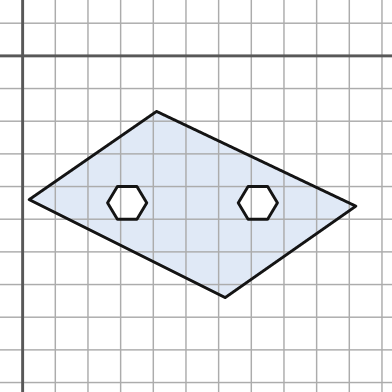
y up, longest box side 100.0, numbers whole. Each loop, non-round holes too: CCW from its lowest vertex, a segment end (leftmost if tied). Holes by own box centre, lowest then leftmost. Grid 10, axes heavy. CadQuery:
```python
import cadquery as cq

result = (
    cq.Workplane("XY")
    .moveTo(62.0, -74.0)
    .lineTo(102.0, -46.0)
    .lineTo(41.0, -17.0)
    .lineTo(2.0, -44.0)
    .close()
    .moveTo(29.0, -50.0)
    .lineTo(35.0, -50.0)
    .lineTo(38.0, -45.0)
    .lineTo(35.0, -40.0)
    .lineTo(29.0, -40.0)
    .lineTo(26.0, -45.0)
    .close()
    .moveTo(69.0, -50.0)
    .lineTo(75.0, -50.0)
    .lineTo(78.0, -45.0)
    .lineTo(75.0, -40.0)
    .lineTo(69.0, -40.0)
    .lineTo(66.0, -45.0)
    .close()
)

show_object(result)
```